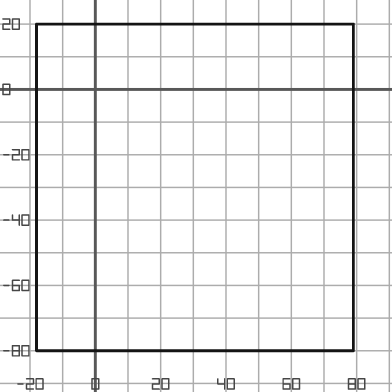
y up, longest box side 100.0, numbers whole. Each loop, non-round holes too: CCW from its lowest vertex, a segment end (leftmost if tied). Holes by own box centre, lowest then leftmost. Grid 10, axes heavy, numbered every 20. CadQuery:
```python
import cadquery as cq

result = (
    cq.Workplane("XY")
    .moveTo(-18.0, -80.0)
    .lineTo(79.0, -80.0)
    .lineTo(79.0, 20.0)
    .lineTo(-18.0, 20.0)
    .close()
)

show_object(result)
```